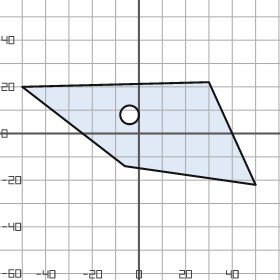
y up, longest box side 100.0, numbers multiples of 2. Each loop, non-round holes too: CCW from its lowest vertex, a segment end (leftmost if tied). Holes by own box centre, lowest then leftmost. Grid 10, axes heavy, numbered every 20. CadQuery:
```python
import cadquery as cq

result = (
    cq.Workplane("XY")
    .moveTo(50.0, -22.0)
    .lineTo(30.0, 22.0)
    .lineTo(-50.0, 20.0)
    .lineTo(-6.0, -14.0)
    .close()
    .moveTo(-4.0, 8.0)
    .circle(4.0)
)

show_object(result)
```